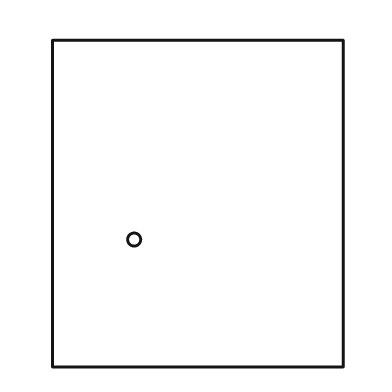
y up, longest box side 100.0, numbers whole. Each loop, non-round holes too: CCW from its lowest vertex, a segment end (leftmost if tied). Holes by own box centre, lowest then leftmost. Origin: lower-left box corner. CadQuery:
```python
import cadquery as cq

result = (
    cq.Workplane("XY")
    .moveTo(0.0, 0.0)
    .lineTo(89.0, 0.0)
    .lineTo(89.0, 100.0)
    .lineTo(0.0, 100.0)
    .close()
    .moveTo(25.0, 39.0)
    .circle(2.0)
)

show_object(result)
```